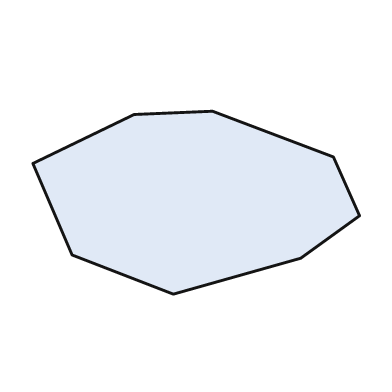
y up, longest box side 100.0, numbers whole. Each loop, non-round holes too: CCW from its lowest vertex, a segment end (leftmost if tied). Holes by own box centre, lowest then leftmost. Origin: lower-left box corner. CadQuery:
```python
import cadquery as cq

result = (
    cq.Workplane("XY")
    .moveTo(43.0, 0.0)
    .lineTo(82.0, 11.0)
    .lineTo(100.0, 24.0)
    .lineTo(92.0, 42.0)
    .lineTo(55.0, 56.0)
    .lineTo(31.0, 55.0)
    .lineTo(0.0, 40.0)
    .lineTo(12.0, 12.0)
    .close()
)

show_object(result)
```